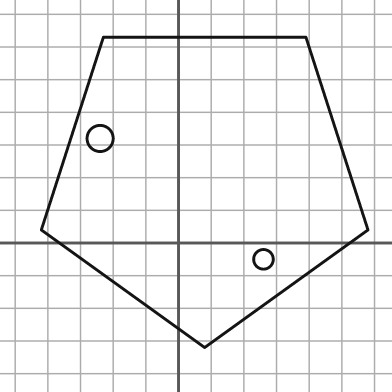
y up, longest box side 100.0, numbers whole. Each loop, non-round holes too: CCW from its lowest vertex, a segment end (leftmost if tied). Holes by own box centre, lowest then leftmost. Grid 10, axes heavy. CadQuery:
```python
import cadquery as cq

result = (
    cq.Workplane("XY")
    .moveTo(8.0, -32.0)
    .lineTo(58.0, 4.0)
    .lineTo(39.0, 63.0)
    .lineTo(-23.0, 63.0)
    .lineTo(-42.0, 4.0)
    .close()
    .moveTo(26.0, -5.0)
    .circle(3.0)
    .moveTo(-24.0, 32.0)
    .circle(4.0)
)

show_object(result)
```